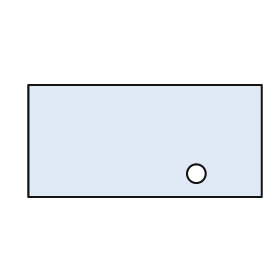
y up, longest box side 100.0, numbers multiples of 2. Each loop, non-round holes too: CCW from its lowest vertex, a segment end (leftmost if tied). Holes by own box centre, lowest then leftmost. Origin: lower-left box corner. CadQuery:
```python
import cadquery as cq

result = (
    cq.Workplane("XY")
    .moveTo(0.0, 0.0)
    .lineTo(100.0, 0.0)
    .lineTo(100.0, 48.0)
    .lineTo(0.0, 48.0)
    .close()
    .moveTo(72.0, 10.0)
    .circle(4.0)
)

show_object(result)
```